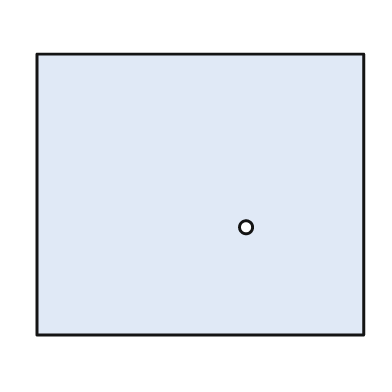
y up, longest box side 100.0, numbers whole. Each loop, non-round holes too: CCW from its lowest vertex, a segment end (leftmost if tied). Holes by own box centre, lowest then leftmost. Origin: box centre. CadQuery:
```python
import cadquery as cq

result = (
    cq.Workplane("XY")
    .moveTo(-50.0, -43.0)
    .lineTo(50.0, -43.0)
    .lineTo(50.0, 43.0)
    .lineTo(-50.0, 43.0)
    .close()
    .moveTo(14.0, -10.0)
    .circle(2.0)
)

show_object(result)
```